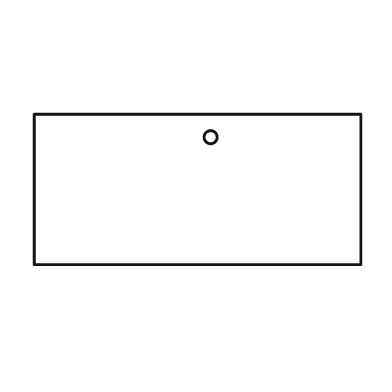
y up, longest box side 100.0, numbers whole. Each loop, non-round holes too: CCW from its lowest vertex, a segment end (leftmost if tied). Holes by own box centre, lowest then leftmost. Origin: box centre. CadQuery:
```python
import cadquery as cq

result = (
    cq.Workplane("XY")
    .moveTo(-50.0, -23.0)
    .lineTo(50.0, -23.0)
    .lineTo(50.0, 23.0)
    .lineTo(-50.0, 23.0)
    .close()
    .moveTo(4.0, 16.0)
    .circle(2.0)
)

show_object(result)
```